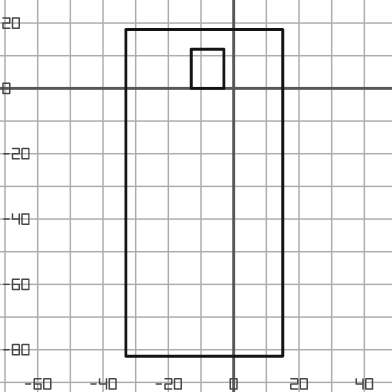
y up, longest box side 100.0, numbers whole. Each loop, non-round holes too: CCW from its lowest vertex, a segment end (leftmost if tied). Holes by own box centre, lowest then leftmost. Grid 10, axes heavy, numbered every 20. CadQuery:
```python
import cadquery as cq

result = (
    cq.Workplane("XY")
    .moveTo(-33.0, -82.0)
    .lineTo(15.0, -82.0)
    .lineTo(15.0, 18.0)
    .lineTo(-33.0, 18.0)
    .close()
    .moveTo(-13.0, 0.0)
    .lineTo(-3.0, 0.0)
    .lineTo(-3.0, 12.0)
    .lineTo(-13.0, 12.0)
    .close()
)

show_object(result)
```